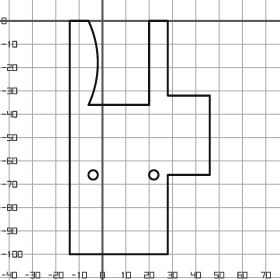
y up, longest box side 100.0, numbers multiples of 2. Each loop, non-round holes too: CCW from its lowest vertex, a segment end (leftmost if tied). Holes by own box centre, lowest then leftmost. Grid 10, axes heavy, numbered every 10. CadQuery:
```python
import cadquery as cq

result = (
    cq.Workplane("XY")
    .moveTo(-14.0, -100.0)
    .lineTo(28.0, -100.0)
    .lineTo(28.0, -66.0)
    .lineTo(46.0, -66.0)
    .lineTo(46.0, -32.0)
    .lineTo(28.0, -32.0)
    .lineTo(28.0, 0.0)
    .lineTo(20.0, 0.0)
    .lineTo(20.0, -36.0)
    .lineTo(-6.0, -36.0)
    .threePointArc((-2.0, -18.0), (-6.0, 0.0))
    .lineTo(-14.0, 0.0)
    .close()
    .moveTo(-4.0, -66.0)
    .circle(2.0)
    .moveTo(22.0, -66.0)
    .circle(2.0)
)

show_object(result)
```